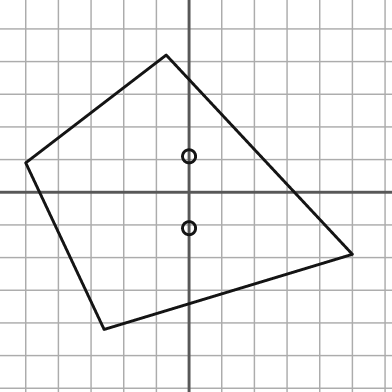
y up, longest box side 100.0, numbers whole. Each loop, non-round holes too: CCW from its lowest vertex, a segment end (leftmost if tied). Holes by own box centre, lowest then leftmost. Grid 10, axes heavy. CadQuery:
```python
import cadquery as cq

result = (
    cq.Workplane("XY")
    .moveTo(-26.0, -42.0)
    .lineTo(50.0, -19.0)
    .lineTo(-7.0, 42.0)
    .lineTo(-50.0, 9.0)
    .close()
    .moveTo(0.0, -11.0)
    .circle(2.0)
    .moveTo(0.0, 11.0)
    .circle(2.0)
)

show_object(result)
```